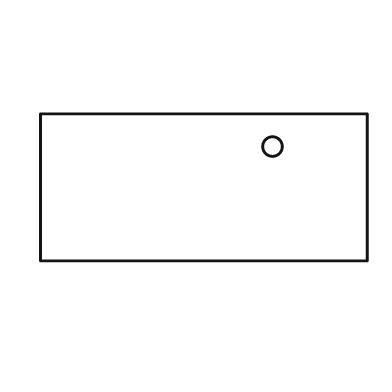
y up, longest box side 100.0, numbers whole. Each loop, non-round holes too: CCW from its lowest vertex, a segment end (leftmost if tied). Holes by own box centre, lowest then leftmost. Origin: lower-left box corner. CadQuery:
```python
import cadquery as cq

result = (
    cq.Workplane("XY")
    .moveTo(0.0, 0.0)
    .lineTo(100.0, 0.0)
    .lineTo(100.0, 45.0)
    .lineTo(0.0, 45.0)
    .close()
    .moveTo(71.0, 35.0)
    .circle(3.0)
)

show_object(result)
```